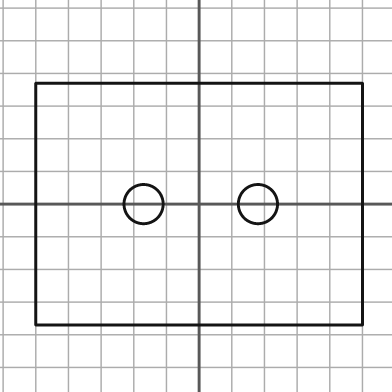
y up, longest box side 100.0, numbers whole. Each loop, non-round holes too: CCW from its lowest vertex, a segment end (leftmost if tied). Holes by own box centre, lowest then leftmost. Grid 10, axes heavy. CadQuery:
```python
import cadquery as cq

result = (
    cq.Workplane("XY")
    .moveTo(-50.0, -37.0)
    .lineTo(50.0, -37.0)
    .lineTo(50.0, 37.0)
    .lineTo(-50.0, 37.0)
    .close()
    .moveTo(-17.0, 0.0)
    .circle(6.0)
    .moveTo(18.0, 0.0)
    .circle(6.0)
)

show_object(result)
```